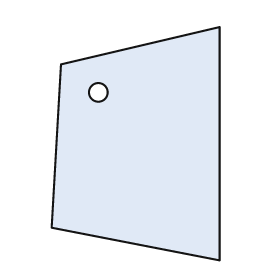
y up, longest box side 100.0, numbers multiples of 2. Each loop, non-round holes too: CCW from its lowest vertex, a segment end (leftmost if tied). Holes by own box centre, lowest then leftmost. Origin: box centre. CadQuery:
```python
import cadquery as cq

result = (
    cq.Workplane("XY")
    .moveTo(36.0, -50.0)
    .lineTo(36.0, 50.0)
    .lineTo(-32.0, 34.0)
    .lineTo(-36.0, -36.0)
    .close()
    .moveTo(-16.0, 22.0)
    .circle(4.0)
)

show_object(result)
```